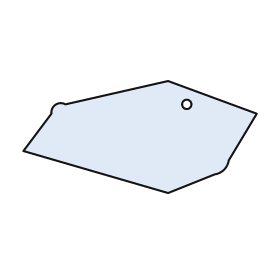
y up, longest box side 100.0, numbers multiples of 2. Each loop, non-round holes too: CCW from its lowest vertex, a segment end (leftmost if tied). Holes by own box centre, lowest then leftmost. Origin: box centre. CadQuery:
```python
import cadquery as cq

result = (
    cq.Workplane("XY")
    .moveTo(12.0, -24.0)
    .lineTo(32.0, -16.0)
    .threePointArc((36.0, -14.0), (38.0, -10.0))
    .lineTo(50.0, 10.0)
    .lineTo(12.0, 24.0)
    .lineTo(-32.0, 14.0)
    .threePointArc((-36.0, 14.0), (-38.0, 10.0))
    .lineTo(-50.0, -6.0)
    .close()
    .moveTo(20.0, 14.0)
    .circle(2.0)
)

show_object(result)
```